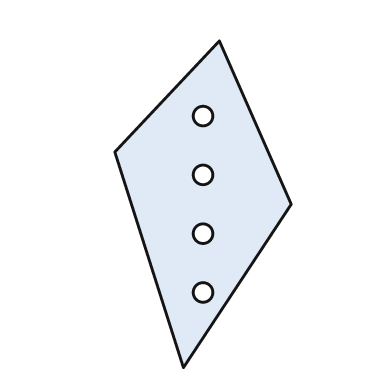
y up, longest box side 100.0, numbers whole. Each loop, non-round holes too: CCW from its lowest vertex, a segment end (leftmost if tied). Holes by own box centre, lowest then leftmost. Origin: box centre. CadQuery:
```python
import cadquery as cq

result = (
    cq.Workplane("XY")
    .moveTo(-6.0, -50.0)
    .lineTo(27.0, 0.0)
    .lineTo(5.0, 50.0)
    .lineTo(-27.0, 16.0)
    .close()
    .moveTo(0.0, -27.0)
    .circle(3.0)
    .moveTo(0.0, -9.0)
    .circle(3.0)
    .moveTo(0.0, 9.0)
    .circle(3.0)
    .moveTo(0.0, 27.0)
    .circle(3.0)
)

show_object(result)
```